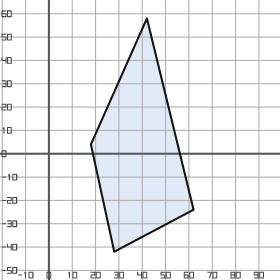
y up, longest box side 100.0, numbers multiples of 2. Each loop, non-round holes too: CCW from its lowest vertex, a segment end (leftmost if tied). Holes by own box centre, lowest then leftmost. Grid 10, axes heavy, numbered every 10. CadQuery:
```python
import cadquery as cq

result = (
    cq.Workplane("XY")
    .moveTo(28.0, -42.0)
    .lineTo(62.0, -24.0)
    .lineTo(42.0, 58.0)
    .lineTo(18.0, 4.0)
    .close()
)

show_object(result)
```